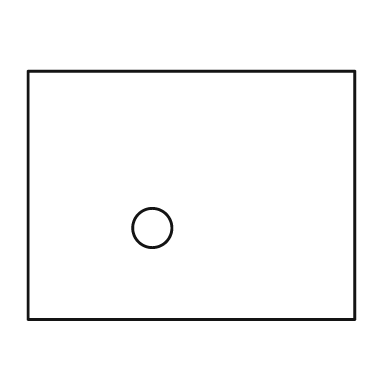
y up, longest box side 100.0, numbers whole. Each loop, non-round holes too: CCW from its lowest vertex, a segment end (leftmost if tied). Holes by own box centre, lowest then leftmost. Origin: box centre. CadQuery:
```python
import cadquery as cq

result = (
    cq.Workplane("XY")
    .moveTo(-50.0, -38.0)
    .lineTo(50.0, -38.0)
    .lineTo(50.0, 38.0)
    .lineTo(-50.0, 38.0)
    .close()
    .moveTo(-12.0, -10.0)
    .circle(6.0)
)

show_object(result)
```